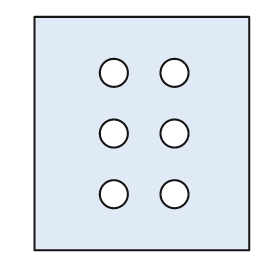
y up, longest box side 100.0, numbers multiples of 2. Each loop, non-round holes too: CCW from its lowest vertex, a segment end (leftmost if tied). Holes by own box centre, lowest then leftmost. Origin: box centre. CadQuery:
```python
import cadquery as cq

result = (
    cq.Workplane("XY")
    .moveTo(-46.0, -50.0)
    .lineTo(46.0, -50.0)
    .lineTo(46.0, 50.0)
    .lineTo(-46.0, 50.0)
    .close()
    .moveTo(-12.0, -26.0)
    .circle(6.0)
    .moveTo(14.0, -26.0)
    .circle(6.0)
    .moveTo(-12.0, 0.0)
    .circle(6.0)
    .moveTo(14.0, 0.0)
    .circle(6.0)
    .moveTo(-12.0, 26.0)
    .circle(6.0)
    .moveTo(14.0, 26.0)
    .circle(6.0)
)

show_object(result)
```